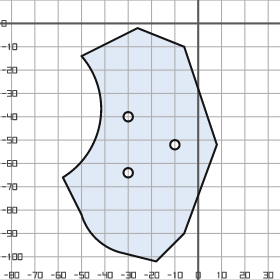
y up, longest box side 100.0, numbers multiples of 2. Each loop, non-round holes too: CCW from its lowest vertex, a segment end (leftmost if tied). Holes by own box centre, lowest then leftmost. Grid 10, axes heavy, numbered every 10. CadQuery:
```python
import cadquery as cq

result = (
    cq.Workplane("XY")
    .moveTo(-18.0, -102.0)
    .lineTo(-6.0, -90.0)
    .lineTo(8.0, -52.0)
    .lineTo(-6.0, -10.0)
    .lineTo(-26.0, -2.0)
    .lineTo(-50.0, -14.0)
    .threePointArc((-42.0, -42.0), (-58.0, -66.0))
    .lineTo(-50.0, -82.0)
    .threePointArc((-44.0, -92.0), (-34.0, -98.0))
    .close()
    .moveTo(-30.0, -64.0)
    .circle(2.0)
    .moveTo(-10.0, -52.0)
    .circle(2.0)
    .moveTo(-30.0, -40.0)
    .circle(2.0)
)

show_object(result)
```